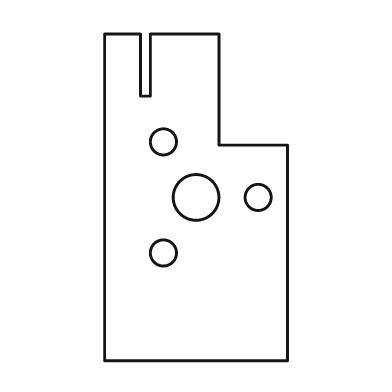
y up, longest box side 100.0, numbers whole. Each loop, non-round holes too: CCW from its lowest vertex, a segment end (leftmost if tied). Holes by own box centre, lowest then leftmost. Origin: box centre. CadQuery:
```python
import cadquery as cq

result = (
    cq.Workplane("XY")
    .moveTo(-28.0, -50.0)
    .lineTo(28.0, -50.0)
    .lineTo(28.0, 16.0)
    .lineTo(7.0, 16.0)
    .lineTo(7.0, 50.0)
    .lineTo(-14.0, 50.0)
    .lineTo(-14.0, 31.0)
    .lineTo(-17.0, 31.0)
    .lineTo(-17.0, 50.0)
    .lineTo(-28.0, 50.0)
    .close()
    .moveTo(-10.0, -17.0)
    .circle(4.0)
    .moveTo(0.0, 0.0)
    .circle(7.0)
    .moveTo(19.0, 0.0)
    .circle(4.0)
    .moveTo(-10.0, 17.0)
    .circle(4.0)
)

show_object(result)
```